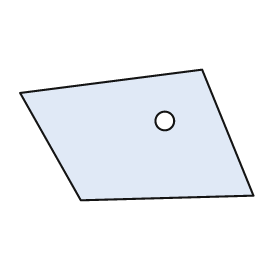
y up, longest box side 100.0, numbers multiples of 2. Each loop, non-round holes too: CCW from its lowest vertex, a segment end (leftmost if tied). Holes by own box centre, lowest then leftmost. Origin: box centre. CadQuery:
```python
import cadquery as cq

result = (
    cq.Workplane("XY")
    .moveTo(-24.0, -28.0)
    .lineTo(50.0, -26.0)
    .lineTo(28.0, 28.0)
    .lineTo(-50.0, 18.0)
    .close()
    .moveTo(12.0, 6.0)
    .circle(4.0)
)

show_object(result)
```